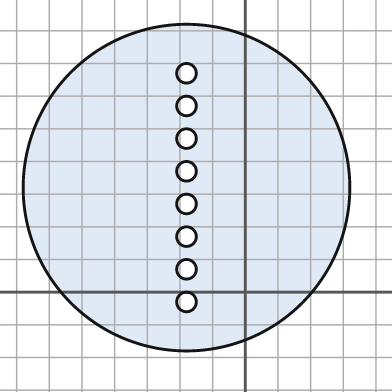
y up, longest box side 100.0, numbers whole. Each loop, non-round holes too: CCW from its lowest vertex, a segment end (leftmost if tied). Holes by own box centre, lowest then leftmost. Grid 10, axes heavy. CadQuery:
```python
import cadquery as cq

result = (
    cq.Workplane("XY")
    .moveTo(-18.0, 32.0)
    .circle(50.0)
    .moveTo(-18.0, -3.0)
    .circle(3.0)
    .moveTo(-18.0, 7.0)
    .circle(3.0)
    .moveTo(-18.0, 17.0)
    .circle(3.0)
    .moveTo(-18.0, 27.0)
    .circle(3.0)
    .moveTo(-18.0, 37.0)
    .circle(3.0)
    .moveTo(-18.0, 47.0)
    .circle(3.0)
    .moveTo(-18.0, 57.0)
    .circle(3.0)
    .moveTo(-18.0, 67.0)
    .circle(3.0)
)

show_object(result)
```